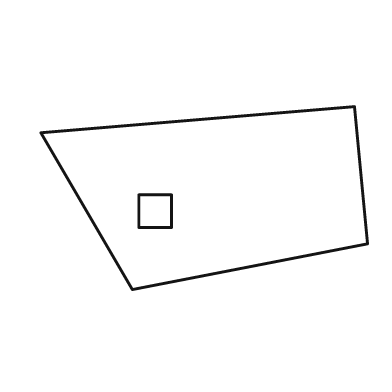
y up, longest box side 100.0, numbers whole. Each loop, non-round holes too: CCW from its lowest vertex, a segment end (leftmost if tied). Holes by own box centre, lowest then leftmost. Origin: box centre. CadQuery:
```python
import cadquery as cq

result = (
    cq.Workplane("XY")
    .moveTo(-22.0, -28.0)
    .lineTo(50.0, -14.0)
    .lineTo(46.0, 28.0)
    .lineTo(-50.0, 20.0)
    .close()
    .moveTo(-20.0, -9.0)
    .lineTo(-10.0, -9.0)
    .lineTo(-10.0, 1.0)
    .lineTo(-20.0, 1.0)
    .close()
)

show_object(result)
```